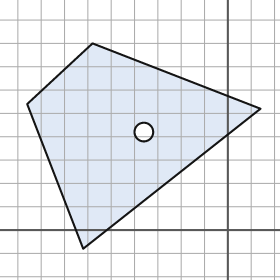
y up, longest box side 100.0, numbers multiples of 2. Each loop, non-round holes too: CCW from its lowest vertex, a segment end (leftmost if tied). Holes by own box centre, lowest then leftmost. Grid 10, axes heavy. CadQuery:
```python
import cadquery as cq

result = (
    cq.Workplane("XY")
    .moveTo(-62.0, -8.0)
    .lineTo(14.0, 52.0)
    .lineTo(-58.0, 80.0)
    .lineTo(-86.0, 54.0)
    .close()
    .moveTo(-36.0, 42.0)
    .circle(4.0)
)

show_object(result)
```